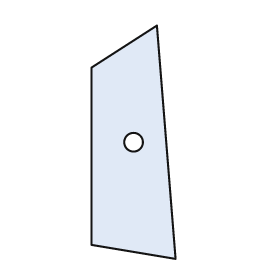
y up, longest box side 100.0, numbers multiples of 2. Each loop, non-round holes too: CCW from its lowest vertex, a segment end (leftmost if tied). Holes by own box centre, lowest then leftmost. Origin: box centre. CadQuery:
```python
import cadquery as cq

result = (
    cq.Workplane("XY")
    .moveTo(18.0, -50.0)
    .lineTo(10.0, 50.0)
    .lineTo(-18.0, 32.0)
    .lineTo(-18.0, -44.0)
    .close()
    .moveTo(0.0, 0.0)
    .circle(4.0)
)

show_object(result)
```